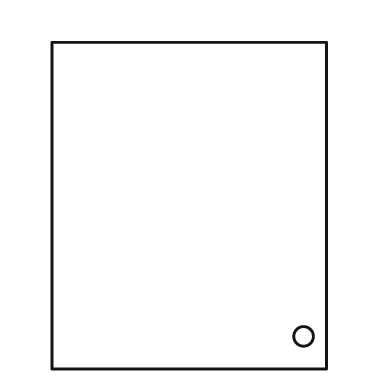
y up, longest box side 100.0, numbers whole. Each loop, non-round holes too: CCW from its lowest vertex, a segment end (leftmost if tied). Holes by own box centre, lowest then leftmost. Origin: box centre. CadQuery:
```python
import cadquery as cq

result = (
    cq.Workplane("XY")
    .moveTo(-42.0, -50.0)
    .lineTo(42.0, -50.0)
    .lineTo(42.0, 50.0)
    .lineTo(-42.0, 50.0)
    .close()
    .moveTo(35.0, -40.0)
    .circle(3.0)
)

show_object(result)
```